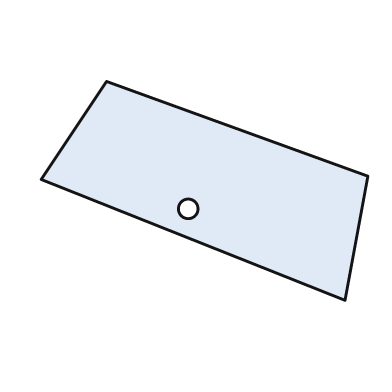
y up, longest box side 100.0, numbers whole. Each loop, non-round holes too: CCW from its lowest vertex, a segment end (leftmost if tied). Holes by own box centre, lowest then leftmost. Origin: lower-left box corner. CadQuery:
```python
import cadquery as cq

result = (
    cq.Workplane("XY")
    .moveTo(93.0, 0.0)
    .lineTo(100.0, 38.0)
    .lineTo(20.0, 67.0)
    .lineTo(0.0, 37.0)
    .close()
    .moveTo(45.0, 28.0)
    .circle(3.0)
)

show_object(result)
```